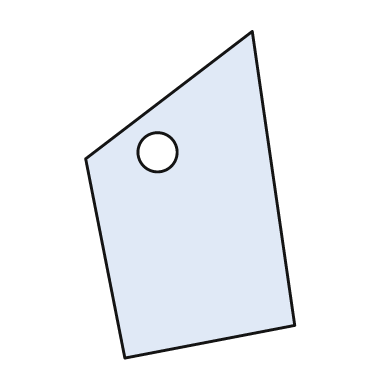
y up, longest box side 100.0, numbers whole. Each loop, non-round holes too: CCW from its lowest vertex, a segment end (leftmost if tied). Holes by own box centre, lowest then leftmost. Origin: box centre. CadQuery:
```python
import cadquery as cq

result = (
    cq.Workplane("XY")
    .moveTo(-20.0, -50.0)
    .lineTo(32.0, -40.0)
    .lineTo(19.0, 50.0)
    .lineTo(-32.0, 11.0)
    .close()
    .moveTo(-10.0, 13.0)
    .circle(6.0)
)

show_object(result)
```